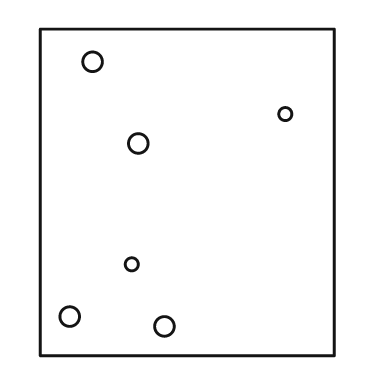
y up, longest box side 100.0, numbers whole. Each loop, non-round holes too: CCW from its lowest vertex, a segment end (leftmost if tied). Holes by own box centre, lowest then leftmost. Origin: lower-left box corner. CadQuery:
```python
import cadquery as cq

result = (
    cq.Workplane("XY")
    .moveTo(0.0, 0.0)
    .lineTo(90.0, 0.0)
    .lineTo(90.0, 100.0)
    .lineTo(0.0, 100.0)
    .close()
    .moveTo(38.0, 9.0)
    .circle(3.0)
    .moveTo(9.0, 12.0)
    .circle(3.0)
    .moveTo(28.0, 28.0)
    .circle(2.0)
    .moveTo(30.0, 65.0)
    .circle(3.0)
    .moveTo(75.0, 74.0)
    .circle(2.0)
    .moveTo(16.0, 90.0)
    .circle(3.0)
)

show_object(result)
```